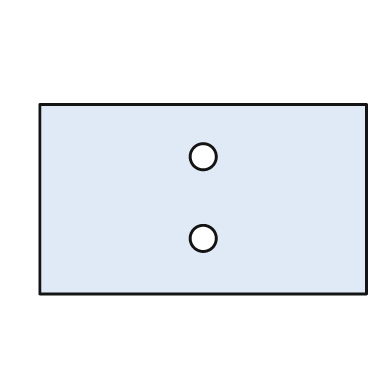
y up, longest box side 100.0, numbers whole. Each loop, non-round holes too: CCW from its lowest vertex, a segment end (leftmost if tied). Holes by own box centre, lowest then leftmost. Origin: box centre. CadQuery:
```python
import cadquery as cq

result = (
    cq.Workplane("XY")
    .moveTo(-50.0, -29.0)
    .lineTo(50.0, -29.0)
    .lineTo(50.0, 29.0)
    .lineTo(-50.0, 29.0)
    .close()
    .moveTo(0.0, -12.0)
    .circle(4.0)
    .moveTo(0.0, 13.0)
    .circle(4.0)
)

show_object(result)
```